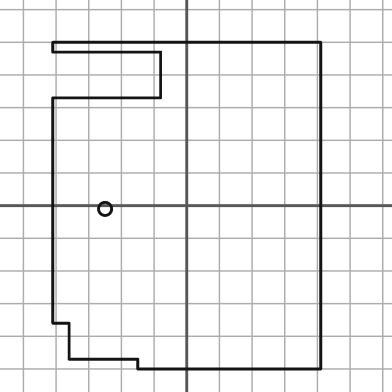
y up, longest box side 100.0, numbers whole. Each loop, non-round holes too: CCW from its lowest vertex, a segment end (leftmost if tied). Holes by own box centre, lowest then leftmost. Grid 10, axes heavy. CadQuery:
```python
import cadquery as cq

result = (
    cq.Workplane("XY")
    .moveTo(-15.0, -50.0)
    .lineTo(41.0, -50.0)
    .lineTo(41.0, 50.0)
    .lineTo(-41.0, 50.0)
    .lineTo(-41.0, 47.0)
    .lineTo(-8.0, 47.0)
    .lineTo(-8.0, 33.0)
    .lineTo(-41.0, 33.0)
    .lineTo(-41.0, -36.0)
    .lineTo(-36.0, -36.0)
    .lineTo(-36.0, -47.0)
    .lineTo(-15.0, -47.0)
    .close()
    .moveTo(-25.0, -1.0)
    .circle(2.0)
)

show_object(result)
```